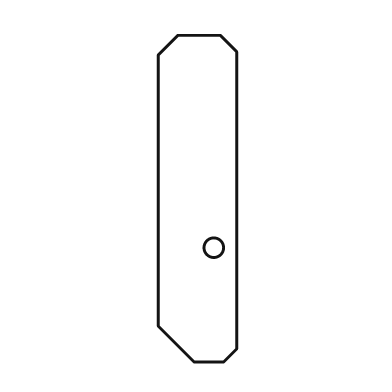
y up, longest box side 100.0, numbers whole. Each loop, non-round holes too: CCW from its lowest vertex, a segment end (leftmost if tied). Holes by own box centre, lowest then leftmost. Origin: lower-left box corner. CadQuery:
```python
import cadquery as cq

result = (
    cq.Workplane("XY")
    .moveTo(11.0, 0.0)
    .lineTo(20.0, 0.0)
    .lineTo(24.0, 4.0)
    .lineTo(24.0, 95.0)
    .lineTo(19.0, 100.0)
    .lineTo(6.0, 100.0)
    .lineTo(0.0, 94.0)
    .lineTo(0.0, 11.0)
    .close()
    .moveTo(17.0, 35.0)
    .circle(3.0)
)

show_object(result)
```